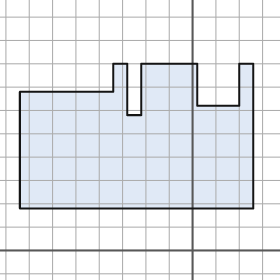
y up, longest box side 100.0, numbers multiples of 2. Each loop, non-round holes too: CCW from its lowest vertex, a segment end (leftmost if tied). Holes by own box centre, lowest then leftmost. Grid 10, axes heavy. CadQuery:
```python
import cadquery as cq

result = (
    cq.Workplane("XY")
    .moveTo(-74.0, 18.0)
    .lineTo(26.0, 18.0)
    .lineTo(26.0, 80.0)
    .lineTo(20.0, 80.0)
    .lineTo(20.0, 62.0)
    .lineTo(2.0, 62.0)
    .lineTo(2.0, 80.0)
    .lineTo(-22.0, 80.0)
    .lineTo(-22.0, 58.0)
    .lineTo(-28.0, 58.0)
    .lineTo(-28.0, 80.0)
    .lineTo(-34.0, 80.0)
    .lineTo(-34.0, 68.0)
    .lineTo(-74.0, 68.0)
    .close()
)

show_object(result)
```